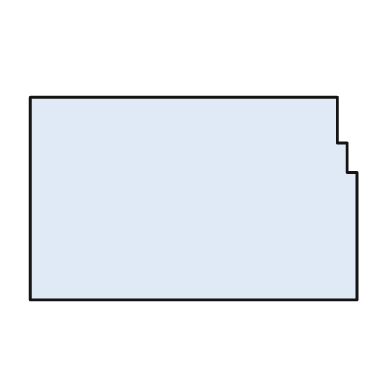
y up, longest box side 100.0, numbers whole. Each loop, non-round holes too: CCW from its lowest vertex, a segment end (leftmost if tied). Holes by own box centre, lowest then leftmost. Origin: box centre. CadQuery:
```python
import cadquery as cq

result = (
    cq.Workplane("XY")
    .moveTo(-50.0, -31.0)
    .lineTo(50.0, -31.0)
    .lineTo(50.0, 8.0)
    .lineTo(47.0, 8.0)
    .lineTo(47.0, 17.0)
    .lineTo(44.0, 17.0)
    .lineTo(44.0, 31.0)
    .lineTo(-50.0, 31.0)
    .close()
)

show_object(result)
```